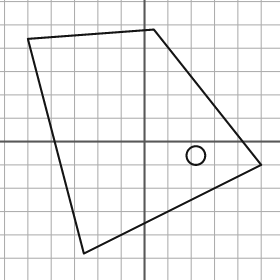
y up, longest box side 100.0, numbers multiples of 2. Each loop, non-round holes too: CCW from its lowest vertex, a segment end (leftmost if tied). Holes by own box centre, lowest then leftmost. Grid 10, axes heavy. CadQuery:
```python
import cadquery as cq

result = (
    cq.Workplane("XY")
    .moveTo(-26.0, -48.0)
    .lineTo(50.0, -10.0)
    .lineTo(4.0, 48.0)
    .lineTo(-50.0, 44.0)
    .close()
    .moveTo(22.0, -6.0)
    .circle(4.0)
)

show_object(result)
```